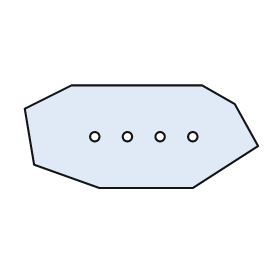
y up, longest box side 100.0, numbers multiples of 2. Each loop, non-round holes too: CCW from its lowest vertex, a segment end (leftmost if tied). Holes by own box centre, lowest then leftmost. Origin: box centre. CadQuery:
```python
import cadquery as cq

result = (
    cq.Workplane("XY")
    .moveTo(-18.0, -22.0)
    .lineTo(22.0, -22.0)
    .lineTo(50.0, -4.0)
    .lineTo(40.0, 14.0)
    .lineTo(26.0, 22.0)
    .lineTo(-30.0, 22.0)
    .lineTo(-50.0, 12.0)
    .lineTo(-46.0, -12.0)
    .close()
    .moveTo(-20.0, 0.0)
    .circle(2.0)
    .moveTo(-6.0, 0.0)
    .circle(2.0)
    .moveTo(8.0, 0.0)
    .circle(2.0)
    .moveTo(22.0, 0.0)
    .circle(2.0)
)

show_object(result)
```